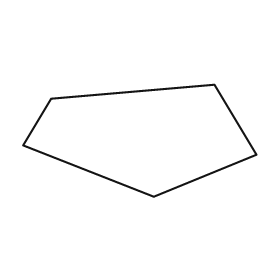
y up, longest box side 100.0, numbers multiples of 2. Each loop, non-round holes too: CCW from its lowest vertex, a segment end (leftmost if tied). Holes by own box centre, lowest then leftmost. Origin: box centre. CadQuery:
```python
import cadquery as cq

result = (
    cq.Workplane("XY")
    .moveTo(6.0, -24.0)
    .lineTo(50.0, -6.0)
    .lineTo(32.0, 24.0)
    .lineTo(-38.0, 18.0)
    .lineTo(-50.0, -2.0)
    .close()
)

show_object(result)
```